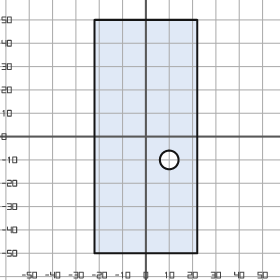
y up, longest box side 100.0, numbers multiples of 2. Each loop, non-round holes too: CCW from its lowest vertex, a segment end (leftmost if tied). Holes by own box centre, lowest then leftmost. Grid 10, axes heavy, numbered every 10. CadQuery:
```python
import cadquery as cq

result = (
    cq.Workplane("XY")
    .moveTo(-22.0, -50.0)
    .lineTo(22.0, -50.0)
    .lineTo(22.0, 50.0)
    .lineTo(-22.0, 50.0)
    .close()
    .moveTo(10.0, -10.0)
    .circle(4.0)
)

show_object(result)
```